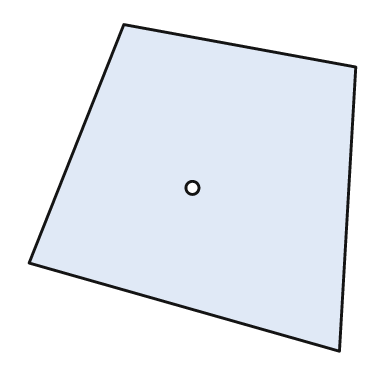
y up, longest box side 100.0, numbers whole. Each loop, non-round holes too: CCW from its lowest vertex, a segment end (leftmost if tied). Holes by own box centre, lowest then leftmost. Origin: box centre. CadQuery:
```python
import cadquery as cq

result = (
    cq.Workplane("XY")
    .moveTo(45.0, -50.0)
    .lineTo(50.0, 37.0)
    .lineTo(-21.0, 50.0)
    .lineTo(-50.0, -23.0)
    .close()
    .moveTo(0.0, 0.0)
    .circle(2.0)
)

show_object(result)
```